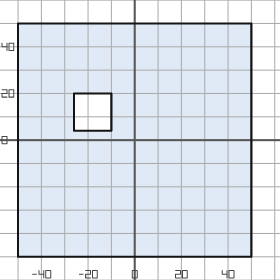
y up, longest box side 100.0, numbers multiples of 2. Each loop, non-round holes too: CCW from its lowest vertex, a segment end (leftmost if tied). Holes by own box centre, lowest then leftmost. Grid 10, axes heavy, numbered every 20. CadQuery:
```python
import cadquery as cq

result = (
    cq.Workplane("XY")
    .moveTo(-50.0, -50.0)
    .lineTo(50.0, -50.0)
    .lineTo(50.0, 50.0)
    .lineTo(-50.0, 50.0)
    .close()
    .moveTo(-26.0, 4.0)
    .lineTo(-10.0, 4.0)
    .lineTo(-10.0, 20.0)
    .lineTo(-26.0, 20.0)
    .close()
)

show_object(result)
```